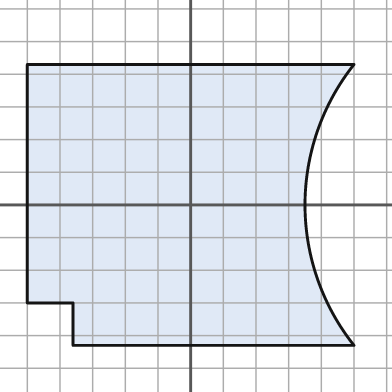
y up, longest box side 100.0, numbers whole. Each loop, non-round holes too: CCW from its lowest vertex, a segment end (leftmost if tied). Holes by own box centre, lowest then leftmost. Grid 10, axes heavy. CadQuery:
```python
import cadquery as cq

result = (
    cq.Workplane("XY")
    .moveTo(-36.0, -43.0)
    .lineTo(50.0, -43.0)
    .threePointArc((35.0, 0.0), (50.0, 43.0))
    .lineTo(-50.0, 43.0)
    .lineTo(-50.0, -30.0)
    .lineTo(-36.0, -30.0)
    .close()
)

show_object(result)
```